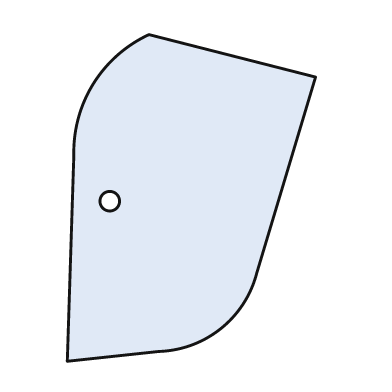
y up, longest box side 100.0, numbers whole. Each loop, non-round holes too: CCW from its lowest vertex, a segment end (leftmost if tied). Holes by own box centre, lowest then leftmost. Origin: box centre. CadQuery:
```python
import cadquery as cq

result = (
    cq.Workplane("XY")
    .moveTo(-38.0, -50.0)
    .lineTo(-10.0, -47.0)
    .threePointArc((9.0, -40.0), (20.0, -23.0))
    .lineTo(38.0, 37.0)
    .lineTo(-13.0, 50.0)
    .threePointArc((-30.0, 35.0), (-36.0, 13.0))
    .close()
    .moveTo(-25.0, -1.0)
    .circle(3.0)
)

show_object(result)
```